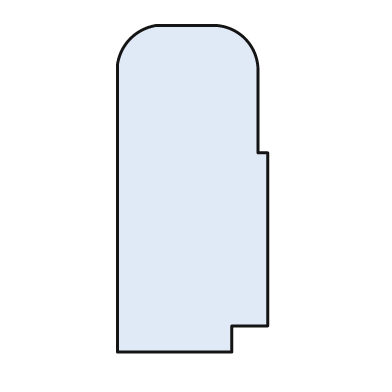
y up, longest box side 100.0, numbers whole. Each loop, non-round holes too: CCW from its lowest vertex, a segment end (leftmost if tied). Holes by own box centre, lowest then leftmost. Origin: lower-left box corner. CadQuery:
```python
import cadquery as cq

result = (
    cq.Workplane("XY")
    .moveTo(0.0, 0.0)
    .lineTo(35.0, 0.0)
    .lineTo(35.0, 8.0)
    .lineTo(46.0, 8.0)
    .lineTo(46.0, 61.0)
    .lineTo(43.0, 61.0)
    .lineTo(43.0, 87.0)
    .threePointArc((39.0, 96.0), (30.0, 100.0))
    .lineTo(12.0, 100.0)
    .threePointArc((4.0, 96.0), (0.0, 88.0))
    .close()
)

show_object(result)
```